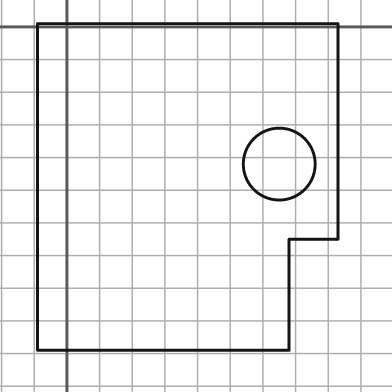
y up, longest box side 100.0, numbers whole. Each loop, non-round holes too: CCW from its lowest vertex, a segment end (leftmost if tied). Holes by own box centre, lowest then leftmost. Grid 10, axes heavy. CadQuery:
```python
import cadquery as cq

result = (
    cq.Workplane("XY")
    .moveTo(-9.0, -99.0)
    .lineTo(68.0, -99.0)
    .lineTo(68.0, -65.0)
    .lineTo(83.0, -65.0)
    .lineTo(83.0, 1.0)
    .lineTo(-9.0, 1.0)
    .close()
    .moveTo(65.0, -42.0)
    .circle(11.0)
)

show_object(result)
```